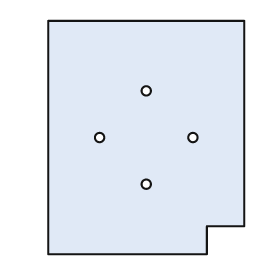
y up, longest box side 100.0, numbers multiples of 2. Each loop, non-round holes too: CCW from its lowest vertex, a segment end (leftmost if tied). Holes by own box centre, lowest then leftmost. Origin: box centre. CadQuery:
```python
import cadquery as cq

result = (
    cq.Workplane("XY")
    .moveTo(-42.0, -50.0)
    .lineTo(26.0, -50.0)
    .lineTo(26.0, -38.0)
    .lineTo(42.0, -38.0)
    .lineTo(42.0, 50.0)
    .lineTo(-42.0, 50.0)
    .close()
    .moveTo(0.0, -20.0)
    .circle(2.0)
    .moveTo(-20.0, 0.0)
    .circle(2.0)
    .moveTo(20.0, 0.0)
    .circle(2.0)
    .moveTo(0.0, 20.0)
    .circle(2.0)
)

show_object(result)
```